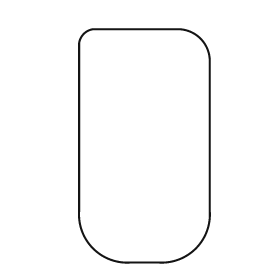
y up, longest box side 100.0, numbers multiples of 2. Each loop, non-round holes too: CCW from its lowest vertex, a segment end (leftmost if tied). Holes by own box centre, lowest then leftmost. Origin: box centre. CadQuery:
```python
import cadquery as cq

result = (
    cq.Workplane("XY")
    .moveTo(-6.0, -50.0)
    .lineTo(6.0, -50.0)
    .threePointArc((22.0, -44.0), (28.0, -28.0))
    .lineTo(28.0, 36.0)
    .threePointArc((24.0, 46.0), (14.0, 50.0))
    .lineTo(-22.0, 50.0)
    .threePointArc((-26.0, 48.0), (-28.0, 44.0))
    .lineTo(-28.0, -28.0)
    .threePointArc((-22.0, -44.0), (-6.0, -50.0))
    .close()
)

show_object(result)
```